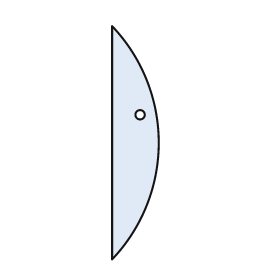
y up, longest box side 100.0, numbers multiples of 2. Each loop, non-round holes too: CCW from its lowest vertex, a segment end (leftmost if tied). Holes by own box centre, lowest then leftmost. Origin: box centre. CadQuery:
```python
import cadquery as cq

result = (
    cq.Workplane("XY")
    .moveTo(-10.0, -50.0)
    .threePointArc((10.0, 0.0), (-10.0, 50.0))
    .close()
    .moveTo(2.0, 12.0)
    .circle(2.0)
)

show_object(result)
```